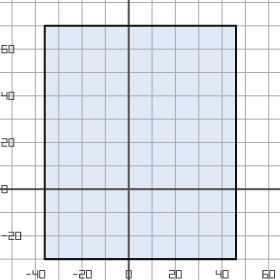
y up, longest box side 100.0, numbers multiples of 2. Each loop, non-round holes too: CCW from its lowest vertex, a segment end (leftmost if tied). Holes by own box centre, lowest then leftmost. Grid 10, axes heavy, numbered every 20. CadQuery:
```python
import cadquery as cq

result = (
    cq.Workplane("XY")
    .moveTo(-36.0, -30.0)
    .lineTo(46.0, -30.0)
    .lineTo(46.0, 70.0)
    .lineTo(-36.0, 70.0)
    .close()
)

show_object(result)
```